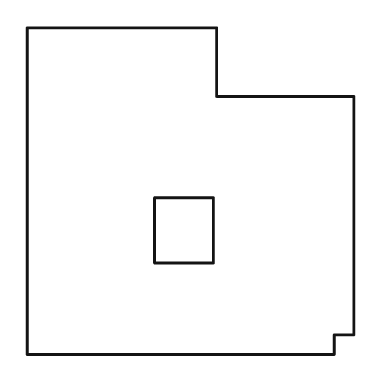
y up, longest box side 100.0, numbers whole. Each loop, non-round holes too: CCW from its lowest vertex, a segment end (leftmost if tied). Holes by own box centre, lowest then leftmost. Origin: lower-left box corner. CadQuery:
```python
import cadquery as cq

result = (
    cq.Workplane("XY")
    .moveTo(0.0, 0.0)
    .lineTo(94.0, 0.0)
    .lineTo(94.0, 6.0)
    .lineTo(100.0, 6.0)
    .lineTo(100.0, 79.0)
    .lineTo(58.0, 79.0)
    .lineTo(58.0, 100.0)
    .lineTo(0.0, 100.0)
    .close()
    .moveTo(39.0, 28.0)
    .lineTo(57.0, 28.0)
    .lineTo(57.0, 48.0)
    .lineTo(39.0, 48.0)
    .close()
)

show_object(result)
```